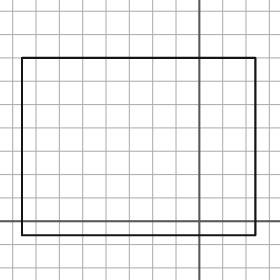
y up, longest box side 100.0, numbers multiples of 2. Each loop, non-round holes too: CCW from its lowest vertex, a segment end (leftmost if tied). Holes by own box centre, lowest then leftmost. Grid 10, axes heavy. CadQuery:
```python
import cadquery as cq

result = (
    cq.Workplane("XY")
    .moveTo(-76.0, -6.0)
    .lineTo(24.0, -6.0)
    .lineTo(24.0, 70.0)
    .lineTo(-76.0, 70.0)
    .close()
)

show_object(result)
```